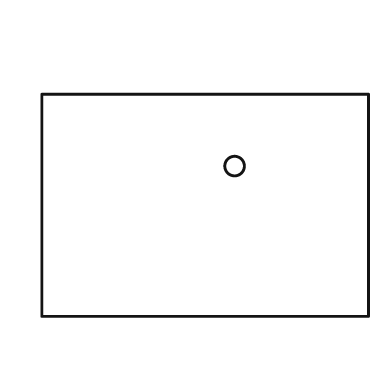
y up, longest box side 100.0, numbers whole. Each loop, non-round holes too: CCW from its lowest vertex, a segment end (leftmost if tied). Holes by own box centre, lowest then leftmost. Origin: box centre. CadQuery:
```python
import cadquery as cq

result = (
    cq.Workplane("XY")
    .moveTo(-50.0, -34.0)
    .lineTo(50.0, -34.0)
    .lineTo(50.0, 34.0)
    .lineTo(-50.0, 34.0)
    .close()
    .moveTo(9.0, 12.0)
    .circle(3.0)
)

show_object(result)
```